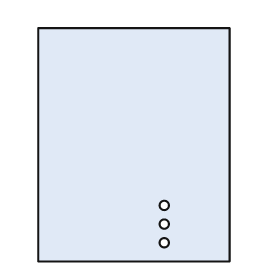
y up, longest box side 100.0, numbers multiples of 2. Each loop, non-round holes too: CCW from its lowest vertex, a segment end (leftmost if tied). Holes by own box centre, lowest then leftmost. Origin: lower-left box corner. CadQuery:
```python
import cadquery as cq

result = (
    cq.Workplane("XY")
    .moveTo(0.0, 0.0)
    .lineTo(82.0, 0.0)
    .lineTo(82.0, 100.0)
    .lineTo(0.0, 100.0)
    .close()
    .moveTo(54.0, 8.0)
    .circle(2.0)
    .moveTo(54.0, 16.0)
    .circle(2.0)
    .moveTo(54.0, 24.0)
    .circle(2.0)
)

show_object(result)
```